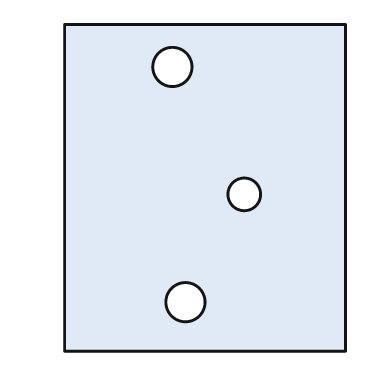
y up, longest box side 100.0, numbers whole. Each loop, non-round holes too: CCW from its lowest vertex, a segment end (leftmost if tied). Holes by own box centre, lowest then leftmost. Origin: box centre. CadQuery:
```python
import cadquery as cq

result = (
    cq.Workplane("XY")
    .moveTo(-43.0, -50.0)
    .lineTo(43.0, -50.0)
    .lineTo(43.0, 50.0)
    .lineTo(-43.0, 50.0)
    .close()
    .moveTo(-6.0, -35.0)
    .circle(6.0)
    .moveTo(12.0, -2.0)
    .circle(5.0)
    .moveTo(-10.0, 37.0)
    .circle(6.0)
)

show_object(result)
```